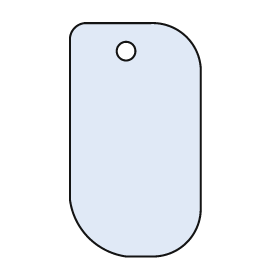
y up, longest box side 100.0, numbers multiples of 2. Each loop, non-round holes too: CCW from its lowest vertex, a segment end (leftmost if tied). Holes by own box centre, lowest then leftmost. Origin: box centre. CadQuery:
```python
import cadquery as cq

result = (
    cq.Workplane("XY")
    .moveTo(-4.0, -50.0)
    .lineTo(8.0, -50.0)
    .threePointArc((22.0, -44.0), (28.0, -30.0))
    .lineTo(28.0, 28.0)
    .threePointArc((22.0, 44.0), (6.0, 50.0))
    .lineTo(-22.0, 50.0)
    .threePointArc((-26.0, 48.0), (-28.0, 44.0))
    .lineTo(-28.0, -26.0)
    .threePointArc((-20.0, -42.0), (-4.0, -50.0))
    .close()
    .moveTo(-4.0, 38.0)
    .circle(4.0)
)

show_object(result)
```